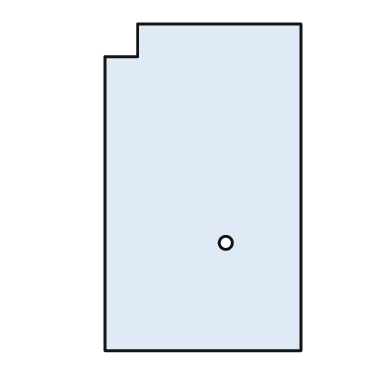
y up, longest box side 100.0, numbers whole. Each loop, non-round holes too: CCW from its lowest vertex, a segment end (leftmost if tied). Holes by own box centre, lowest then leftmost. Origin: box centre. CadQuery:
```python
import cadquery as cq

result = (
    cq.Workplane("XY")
    .moveTo(-30.0, -50.0)
    .lineTo(30.0, -50.0)
    .lineTo(30.0, 50.0)
    .lineTo(-20.0, 50.0)
    .lineTo(-20.0, 40.0)
    .lineTo(-30.0, 40.0)
    .close()
    .moveTo(7.0, -17.0)
    .circle(2.0)
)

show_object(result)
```